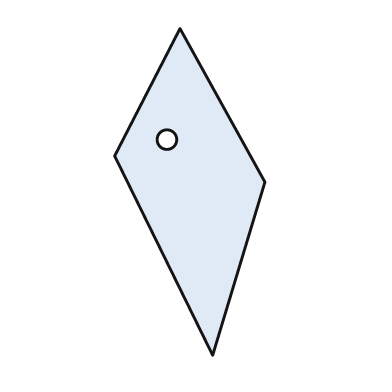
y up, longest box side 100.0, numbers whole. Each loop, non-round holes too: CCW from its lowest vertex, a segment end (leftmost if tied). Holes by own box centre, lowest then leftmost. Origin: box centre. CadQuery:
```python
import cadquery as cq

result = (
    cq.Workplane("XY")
    .moveTo(7.0, -50.0)
    .lineTo(23.0, 3.0)
    .lineTo(-3.0, 50.0)
    .lineTo(-23.0, 11.0)
    .close()
    .moveTo(-7.0, 16.0)
    .circle(3.0)
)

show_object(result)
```